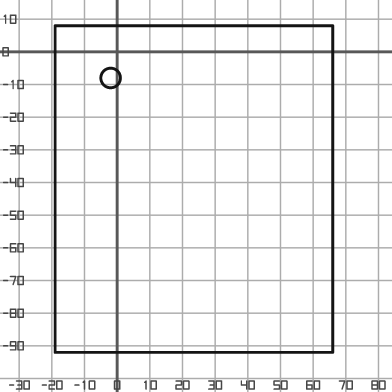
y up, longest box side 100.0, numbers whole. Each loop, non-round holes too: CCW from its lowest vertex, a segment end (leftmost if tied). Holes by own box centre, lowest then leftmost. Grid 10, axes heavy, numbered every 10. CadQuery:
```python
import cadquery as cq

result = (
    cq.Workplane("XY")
    .moveTo(-19.0, -92.0)
    .lineTo(66.0, -92.0)
    .lineTo(66.0, 8.0)
    .lineTo(-19.0, 8.0)
    .close()
    .moveTo(-2.0, -8.0)
    .circle(3.0)
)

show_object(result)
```